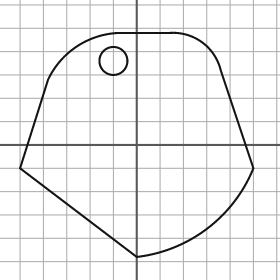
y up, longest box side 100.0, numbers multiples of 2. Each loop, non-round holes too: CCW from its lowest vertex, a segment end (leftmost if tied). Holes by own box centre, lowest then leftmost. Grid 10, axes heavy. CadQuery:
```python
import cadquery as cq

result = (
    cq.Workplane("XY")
    .moveTo(0.0, -48.0)
    .threePointArc((30.0, -36.0), (50.0, -10.0))
    .lineTo(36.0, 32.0)
    .threePointArc((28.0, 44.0), (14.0, 48.0))
    .lineTo(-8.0, 48.0)
    .threePointArc((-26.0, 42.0), (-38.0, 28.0))
    .lineTo(-50.0, -10.0)
    .close()
    .moveTo(-10.0, 36.0)
    .circle(6.0)
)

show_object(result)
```